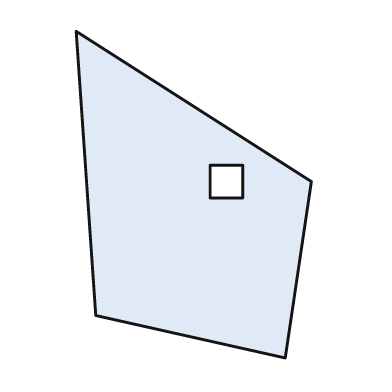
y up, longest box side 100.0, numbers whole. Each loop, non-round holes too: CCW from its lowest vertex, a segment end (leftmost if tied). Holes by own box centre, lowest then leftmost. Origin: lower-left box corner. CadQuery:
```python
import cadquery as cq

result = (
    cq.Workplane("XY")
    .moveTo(64.0, 0.0)
    .lineTo(72.0, 54.0)
    .lineTo(0.0, 100.0)
    .lineTo(6.0, 13.0)
    .close()
    .moveTo(41.0, 49.0)
    .lineTo(51.0, 49.0)
    .lineTo(51.0, 59.0)
    .lineTo(41.0, 59.0)
    .close()
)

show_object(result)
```